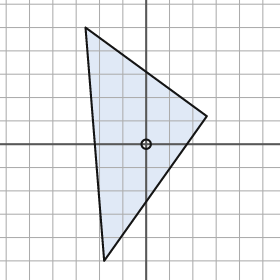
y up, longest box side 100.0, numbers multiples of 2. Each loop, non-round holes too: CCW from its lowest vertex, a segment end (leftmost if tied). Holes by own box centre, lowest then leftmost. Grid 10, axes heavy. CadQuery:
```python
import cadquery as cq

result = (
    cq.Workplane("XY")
    .moveTo(-18.0, -50.0)
    .lineTo(26.0, 12.0)
    .lineTo(-26.0, 50.0)
    .close()
    .moveTo(0.0, 0.0)
    .circle(2.0)
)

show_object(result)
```